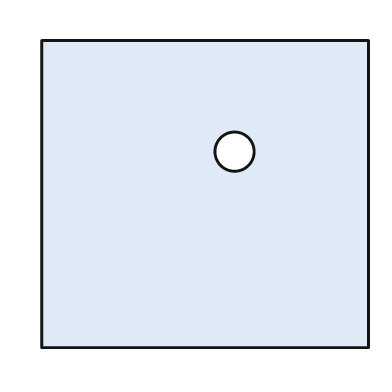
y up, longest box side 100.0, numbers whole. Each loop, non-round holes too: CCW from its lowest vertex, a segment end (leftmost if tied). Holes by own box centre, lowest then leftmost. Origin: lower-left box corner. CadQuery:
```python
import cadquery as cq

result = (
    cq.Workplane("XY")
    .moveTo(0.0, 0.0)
    .lineTo(100.0, 0.0)
    .lineTo(100.0, 94.0)
    .lineTo(0.0, 94.0)
    .close()
    .moveTo(59.0, 60.0)
    .circle(6.0)
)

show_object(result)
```